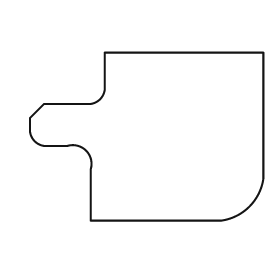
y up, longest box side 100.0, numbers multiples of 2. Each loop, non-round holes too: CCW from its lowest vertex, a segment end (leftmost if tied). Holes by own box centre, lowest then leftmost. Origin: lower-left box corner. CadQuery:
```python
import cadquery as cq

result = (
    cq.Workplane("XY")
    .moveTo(26.0, 0.0)
    .lineTo(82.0, 0.0)
    .threePointArc((94.0, 6.0), (100.0, 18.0))
    .lineTo(100.0, 72.0)
    .lineTo(32.0, 72.0)
    .lineTo(32.0, 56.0)
    .threePointArc((30.0, 52.0), (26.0, 50.0))
    .lineTo(6.0, 50.0)
    .lineTo(0.0, 44.0)
    .lineTo(0.0, 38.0)
    .threePointArc((2.0, 34.0), (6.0, 32.0))
    .lineTo(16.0, 32.0)
    .threePointArc((24.0, 30.0), (26.0, 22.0))
    .close()
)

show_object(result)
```